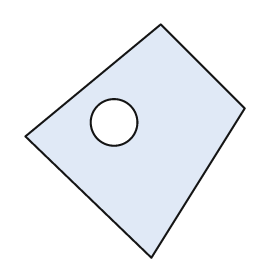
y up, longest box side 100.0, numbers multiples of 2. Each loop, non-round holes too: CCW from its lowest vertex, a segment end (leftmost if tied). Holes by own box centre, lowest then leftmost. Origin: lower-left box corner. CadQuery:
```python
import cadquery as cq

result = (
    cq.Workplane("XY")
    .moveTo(54.0, 0.0)
    .lineTo(94.0, 64.0)
    .lineTo(58.0, 100.0)
    .lineTo(0.0, 52.0)
    .close()
    .moveTo(38.0, 58.0)
    .circle(10.0)
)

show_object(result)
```